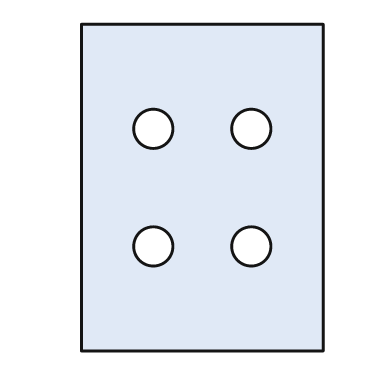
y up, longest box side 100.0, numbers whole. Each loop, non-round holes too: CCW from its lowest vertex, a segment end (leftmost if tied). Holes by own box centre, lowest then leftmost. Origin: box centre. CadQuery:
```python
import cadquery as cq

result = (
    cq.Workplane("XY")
    .moveTo(-37.0, -50.0)
    .lineTo(37.0, -50.0)
    .lineTo(37.0, 50.0)
    .lineTo(-37.0, 50.0)
    .close()
    .moveTo(-15.0, -18.0)
    .circle(6.0)
    .moveTo(15.0, -18.0)
    .circle(6.0)
    .moveTo(-15.0, 18.0)
    .circle(6.0)
    .moveTo(15.0, 18.0)
    .circle(6.0)
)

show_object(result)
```